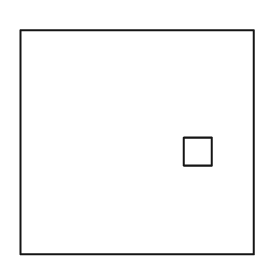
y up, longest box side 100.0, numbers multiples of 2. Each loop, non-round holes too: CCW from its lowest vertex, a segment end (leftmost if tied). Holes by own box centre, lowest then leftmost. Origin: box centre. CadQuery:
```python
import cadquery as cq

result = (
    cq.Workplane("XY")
    .moveTo(-50.0, -48.0)
    .lineTo(50.0, -48.0)
    .lineTo(50.0, 48.0)
    .lineTo(-50.0, 48.0)
    .close()
    .moveTo(20.0, -10.0)
    .lineTo(32.0, -10.0)
    .lineTo(32.0, 2.0)
    .lineTo(20.0, 2.0)
    .close()
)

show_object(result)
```